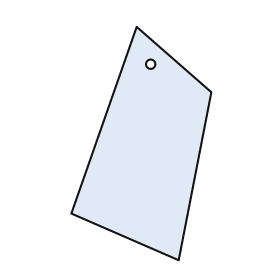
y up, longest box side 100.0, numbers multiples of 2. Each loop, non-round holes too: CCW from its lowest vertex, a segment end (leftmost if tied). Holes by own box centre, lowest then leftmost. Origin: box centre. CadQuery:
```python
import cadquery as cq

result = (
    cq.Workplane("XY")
    .moveTo(16.0, -50.0)
    .lineTo(30.0, 22.0)
    .lineTo(-2.0, 50.0)
    .lineTo(-30.0, -30.0)
    .close()
    .moveTo(4.0, 34.0)
    .circle(2.0)
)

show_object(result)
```